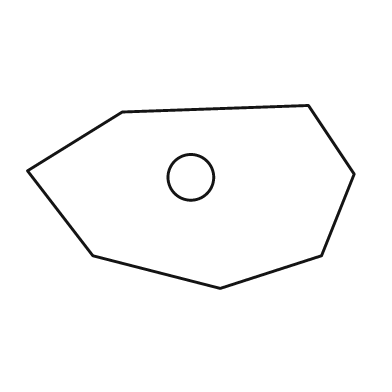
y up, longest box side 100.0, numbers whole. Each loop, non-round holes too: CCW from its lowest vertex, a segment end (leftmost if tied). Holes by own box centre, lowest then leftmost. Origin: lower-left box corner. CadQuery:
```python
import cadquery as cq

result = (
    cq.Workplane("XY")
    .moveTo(59.0, 0.0)
    .lineTo(90.0, 10.0)
    .lineTo(100.0, 35.0)
    .lineTo(86.0, 56.0)
    .lineTo(29.0, 54.0)
    .lineTo(0.0, 36.0)
    .lineTo(20.0, 10.0)
    .close()
    .moveTo(50.0, 34.0)
    .circle(7.0)
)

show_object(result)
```